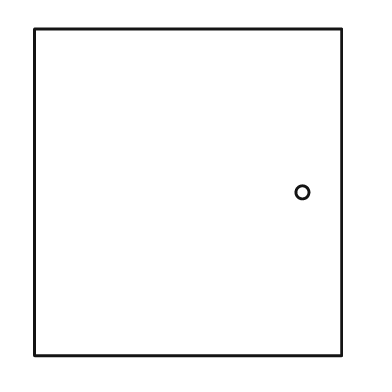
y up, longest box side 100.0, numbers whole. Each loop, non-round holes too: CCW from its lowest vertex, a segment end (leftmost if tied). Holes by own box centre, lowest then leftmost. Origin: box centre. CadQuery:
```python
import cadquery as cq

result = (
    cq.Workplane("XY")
    .moveTo(-47.0, -50.0)
    .lineTo(47.0, -50.0)
    .lineTo(47.0, 50.0)
    .lineTo(-47.0, 50.0)
    .close()
    .moveTo(35.0, 0.0)
    .circle(2.0)
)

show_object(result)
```